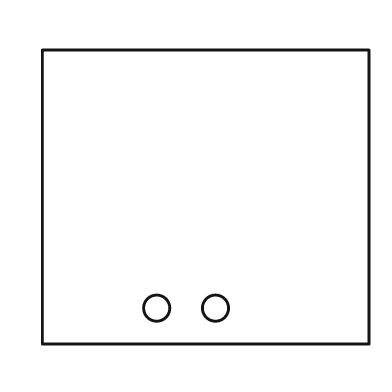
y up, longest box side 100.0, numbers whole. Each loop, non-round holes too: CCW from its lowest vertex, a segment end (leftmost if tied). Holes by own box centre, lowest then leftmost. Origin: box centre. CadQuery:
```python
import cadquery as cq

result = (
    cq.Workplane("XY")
    .moveTo(-50.0, -45.0)
    .lineTo(50.0, -45.0)
    .lineTo(50.0, 45.0)
    .lineTo(-50.0, 45.0)
    .close()
    .moveTo(-15.0, -34.0)
    .circle(4.0)
    .moveTo(3.0, -34.0)
    .circle(4.0)
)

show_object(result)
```